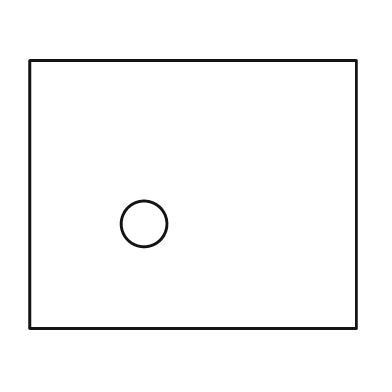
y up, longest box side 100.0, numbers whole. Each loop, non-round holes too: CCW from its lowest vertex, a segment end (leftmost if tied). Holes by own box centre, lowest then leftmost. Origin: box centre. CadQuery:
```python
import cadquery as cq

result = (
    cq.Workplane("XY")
    .moveTo(-50.0, -41.0)
    .lineTo(50.0, -41.0)
    .lineTo(50.0, 41.0)
    .lineTo(-50.0, 41.0)
    .close()
    .moveTo(-15.0, -9.0)
    .circle(7.0)
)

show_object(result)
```